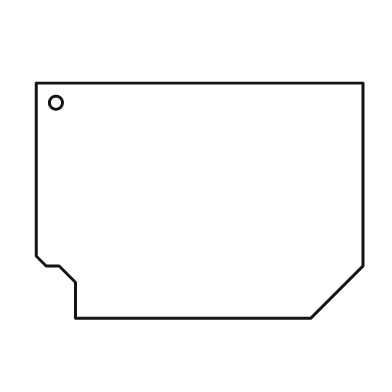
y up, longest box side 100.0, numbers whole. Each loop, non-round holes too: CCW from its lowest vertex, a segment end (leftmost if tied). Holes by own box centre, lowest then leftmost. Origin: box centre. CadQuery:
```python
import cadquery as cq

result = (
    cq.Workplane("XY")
    .moveTo(-38.0, -36.0)
    .lineTo(34.0, -36.0)
    .lineTo(50.0, -20.0)
    .lineTo(50.0, 36.0)
    .lineTo(-50.0, 36.0)
    .lineTo(-50.0, -17.0)
    .lineTo(-47.0, -20.0)
    .lineTo(-43.0, -20.0)
    .lineTo(-38.0, -25.0)
    .close()
    .moveTo(-44.0, 30.0)
    .circle(2.0)
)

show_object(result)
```